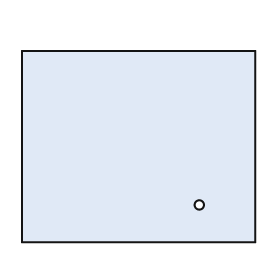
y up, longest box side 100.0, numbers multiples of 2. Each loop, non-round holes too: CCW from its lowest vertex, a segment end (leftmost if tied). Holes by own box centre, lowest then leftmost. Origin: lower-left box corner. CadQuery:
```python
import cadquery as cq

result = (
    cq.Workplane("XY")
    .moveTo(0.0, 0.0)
    .lineTo(100.0, 0.0)
    .lineTo(100.0, 82.0)
    .lineTo(0.0, 82.0)
    .close()
    .moveTo(76.0, 16.0)
    .circle(2.0)
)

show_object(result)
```